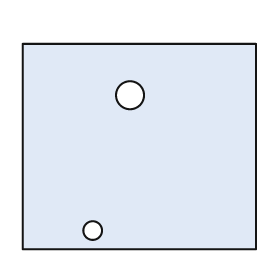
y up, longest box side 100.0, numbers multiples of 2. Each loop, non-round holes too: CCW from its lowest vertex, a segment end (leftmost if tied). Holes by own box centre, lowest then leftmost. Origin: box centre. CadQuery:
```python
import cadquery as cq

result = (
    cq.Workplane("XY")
    .moveTo(-50.0, -44.0)
    .lineTo(50.0, -44.0)
    .lineTo(50.0, 44.0)
    .lineTo(-50.0, 44.0)
    .close()
    .moveTo(-20.0, -36.0)
    .circle(4.0)
    .moveTo(-4.0, 22.0)
    .circle(6.0)
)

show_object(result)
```